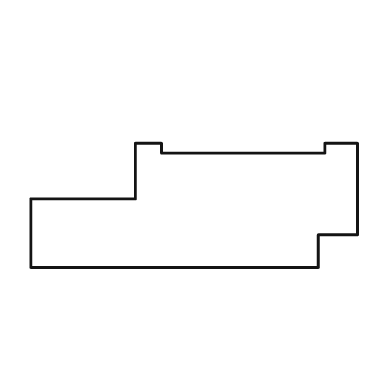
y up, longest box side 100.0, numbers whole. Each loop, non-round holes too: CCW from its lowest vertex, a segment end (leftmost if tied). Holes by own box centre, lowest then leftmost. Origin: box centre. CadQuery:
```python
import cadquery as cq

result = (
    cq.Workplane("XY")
    .moveTo(-50.0, -19.0)
    .lineTo(38.0, -19.0)
    .lineTo(38.0, -9.0)
    .lineTo(50.0, -9.0)
    .lineTo(50.0, 19.0)
    .lineTo(40.0, 19.0)
    .lineTo(40.0, 16.0)
    .lineTo(-10.0, 16.0)
    .lineTo(-10.0, 19.0)
    .lineTo(-18.0, 19.0)
    .lineTo(-18.0, 2.0)
    .lineTo(-50.0, 2.0)
    .close()
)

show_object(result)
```